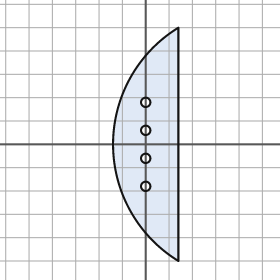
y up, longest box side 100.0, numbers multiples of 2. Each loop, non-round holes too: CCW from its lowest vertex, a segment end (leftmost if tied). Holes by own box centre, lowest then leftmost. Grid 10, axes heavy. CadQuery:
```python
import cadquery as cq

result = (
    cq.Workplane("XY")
    .moveTo(14.0, -50.0)
    .lineTo(14.0, 50.0)
    .threePointArc((-14.0, 0.0), (14.0, -50.0))
    .close()
    .moveTo(0.0, -18.0)
    .circle(2.0)
    .moveTo(0.0, -6.0)
    .circle(2.0)
    .moveTo(0.0, 6.0)
    .circle(2.0)
    .moveTo(0.0, 18.0)
    .circle(2.0)
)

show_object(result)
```